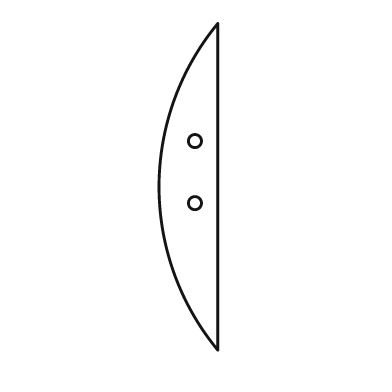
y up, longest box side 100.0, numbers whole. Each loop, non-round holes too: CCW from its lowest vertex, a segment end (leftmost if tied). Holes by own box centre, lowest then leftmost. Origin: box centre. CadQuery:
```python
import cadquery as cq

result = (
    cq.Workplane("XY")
    .moveTo(9.0, -50.0)
    .lineTo(9.0, 50.0)
    .threePointArc((-9.0, 0.0), (9.0, -50.0))
    .close()
    .moveTo(2.0, -5.0)
    .circle(2.0)
    .moveTo(2.0, 14.0)
    .circle(2.0)
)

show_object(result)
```